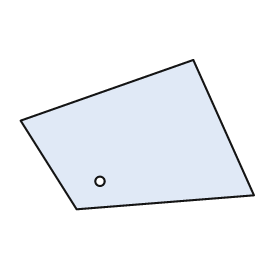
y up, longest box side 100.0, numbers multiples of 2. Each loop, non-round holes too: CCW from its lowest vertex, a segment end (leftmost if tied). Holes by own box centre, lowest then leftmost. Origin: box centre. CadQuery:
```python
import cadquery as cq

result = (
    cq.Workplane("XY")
    .moveTo(-26.0, -32.0)
    .lineTo(50.0, -26.0)
    .lineTo(24.0, 32.0)
    .lineTo(-50.0, 6.0)
    .close()
    .moveTo(-16.0, -20.0)
    .circle(2.0)
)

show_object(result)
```